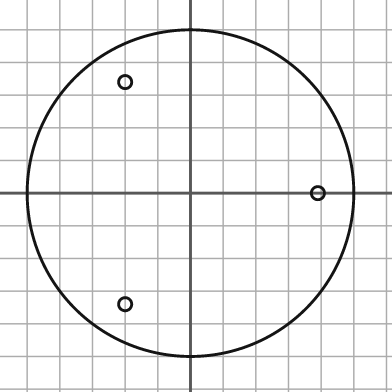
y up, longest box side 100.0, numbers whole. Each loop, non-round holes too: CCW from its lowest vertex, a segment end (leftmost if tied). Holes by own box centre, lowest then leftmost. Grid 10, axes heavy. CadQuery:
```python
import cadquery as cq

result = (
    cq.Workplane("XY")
    .moveTo(0.0, 0.0)
    .circle(50.0)
    .moveTo(-20.0, -34.0)
    .circle(2.0)
    .moveTo(39.0, 0.0)
    .circle(2.0)
    .moveTo(-20.0, 34.0)
    .circle(2.0)
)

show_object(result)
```